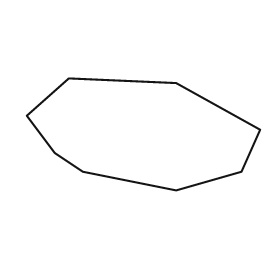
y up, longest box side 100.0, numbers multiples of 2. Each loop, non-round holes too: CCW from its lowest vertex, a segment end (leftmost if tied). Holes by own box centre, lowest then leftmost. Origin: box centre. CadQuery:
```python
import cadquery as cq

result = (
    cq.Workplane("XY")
    .moveTo(14.0, -24.0)
    .lineTo(42.0, -16.0)
    .lineTo(50.0, 2.0)
    .lineTo(14.0, 22.0)
    .lineTo(-32.0, 24.0)
    .lineTo(-50.0, 8.0)
    .lineTo(-38.0, -8.0)
    .lineTo(-26.0, -16.0)
    .close()
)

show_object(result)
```